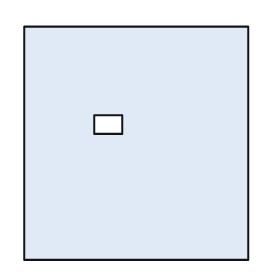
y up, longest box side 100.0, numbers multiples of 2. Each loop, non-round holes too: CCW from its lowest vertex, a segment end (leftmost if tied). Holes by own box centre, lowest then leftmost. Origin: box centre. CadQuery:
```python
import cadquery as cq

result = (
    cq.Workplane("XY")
    .moveTo(-48.0, -50.0)
    .lineTo(48.0, -50.0)
    .lineTo(48.0, 50.0)
    .lineTo(-48.0, 50.0)
    .close()
    .moveTo(-18.0, 4.0)
    .lineTo(-6.0, 4.0)
    .lineTo(-6.0, 12.0)
    .lineTo(-18.0, 12.0)
    .close()
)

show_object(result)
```